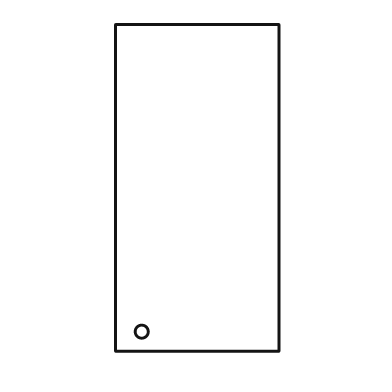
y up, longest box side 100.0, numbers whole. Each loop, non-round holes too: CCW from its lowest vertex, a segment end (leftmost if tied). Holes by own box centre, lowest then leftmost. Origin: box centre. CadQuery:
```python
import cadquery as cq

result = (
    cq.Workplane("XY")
    .moveTo(-25.0, -50.0)
    .lineTo(25.0, -50.0)
    .lineTo(25.0, 50.0)
    .lineTo(-25.0, 50.0)
    .close()
    .moveTo(-17.0, -44.0)
    .circle(2.0)
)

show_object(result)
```